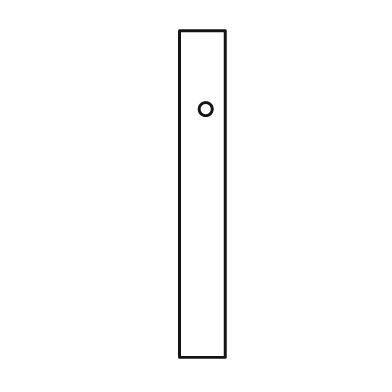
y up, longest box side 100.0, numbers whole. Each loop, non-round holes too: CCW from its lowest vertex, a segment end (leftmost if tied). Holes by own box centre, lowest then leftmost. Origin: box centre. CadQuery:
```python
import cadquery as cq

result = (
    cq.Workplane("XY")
    .moveTo(-7.0, -50.0)
    .lineTo(7.0, -50.0)
    .lineTo(7.0, 50.0)
    .lineTo(-7.0, 50.0)
    .close()
    .moveTo(1.0, 26.0)
    .circle(2.0)
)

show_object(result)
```